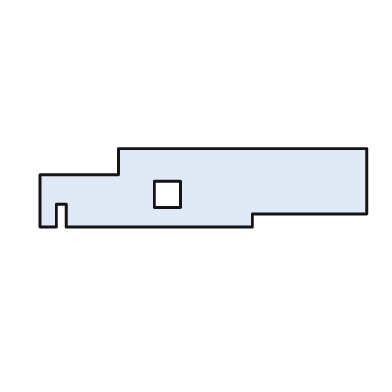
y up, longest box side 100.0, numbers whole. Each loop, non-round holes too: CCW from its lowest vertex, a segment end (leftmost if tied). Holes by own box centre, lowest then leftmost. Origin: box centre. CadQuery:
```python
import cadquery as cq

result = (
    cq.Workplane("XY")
    .moveTo(-50.0, -12.0)
    .lineTo(-45.0, -12.0)
    .lineTo(-45.0, -5.0)
    .lineTo(-42.0, -5.0)
    .lineTo(-42.0, -12.0)
    .lineTo(15.0, -12.0)
    .lineTo(15.0, -8.0)
    .lineTo(50.0, -8.0)
    .lineTo(50.0, 12.0)
    .lineTo(-26.0, 12.0)
    .lineTo(-26.0, 4.0)
    .lineTo(-50.0, 4.0)
    .close()
    .moveTo(-15.0, -6.0)
    .lineTo(-7.0, -6.0)
    .lineTo(-7.0, 2.0)
    .lineTo(-15.0, 2.0)
    .close()
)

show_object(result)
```